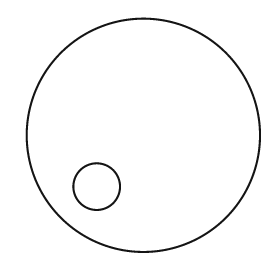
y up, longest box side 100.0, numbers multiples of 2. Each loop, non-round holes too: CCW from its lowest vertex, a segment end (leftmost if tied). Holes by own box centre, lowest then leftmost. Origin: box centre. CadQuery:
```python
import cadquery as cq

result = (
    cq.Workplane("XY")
    .moveTo(0.0, 0.0)
    .circle(50.0)
    .moveTo(-20.0, -22.0)
    .circle(10.0)
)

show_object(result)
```